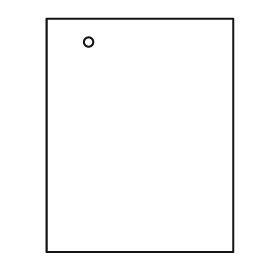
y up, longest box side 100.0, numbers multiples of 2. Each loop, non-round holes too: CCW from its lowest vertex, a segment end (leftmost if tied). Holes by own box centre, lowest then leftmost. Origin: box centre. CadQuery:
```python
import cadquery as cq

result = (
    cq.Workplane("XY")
    .moveTo(-40.0, -50.0)
    .lineTo(40.0, -50.0)
    .lineTo(40.0, 50.0)
    .lineTo(-40.0, 50.0)
    .close()
    .moveTo(-22.0, 40.0)
    .circle(2.0)
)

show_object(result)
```